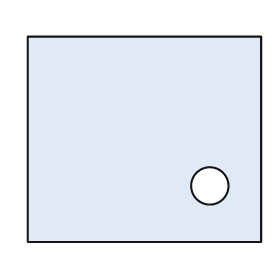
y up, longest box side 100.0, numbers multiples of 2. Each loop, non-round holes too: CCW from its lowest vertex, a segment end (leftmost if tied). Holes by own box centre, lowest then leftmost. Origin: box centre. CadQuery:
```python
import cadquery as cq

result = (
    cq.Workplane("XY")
    .moveTo(-50.0, -44.0)
    .lineTo(50.0, -44.0)
    .lineTo(50.0, 44.0)
    .lineTo(-50.0, 44.0)
    .close()
    .moveTo(28.0, -20.0)
    .circle(8.0)
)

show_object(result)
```